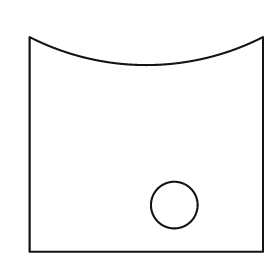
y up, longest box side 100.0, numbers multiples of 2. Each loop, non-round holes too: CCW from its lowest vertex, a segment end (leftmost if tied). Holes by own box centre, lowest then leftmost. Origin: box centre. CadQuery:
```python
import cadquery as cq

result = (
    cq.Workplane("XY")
    .moveTo(-50.0, -46.0)
    .lineTo(50.0, -46.0)
    .lineTo(50.0, 46.0)
    .threePointArc((0.0, 34.0), (-50.0, 46.0))
    .close()
    .moveTo(12.0, -26.0)
    .circle(10.0)
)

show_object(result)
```